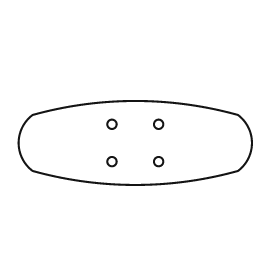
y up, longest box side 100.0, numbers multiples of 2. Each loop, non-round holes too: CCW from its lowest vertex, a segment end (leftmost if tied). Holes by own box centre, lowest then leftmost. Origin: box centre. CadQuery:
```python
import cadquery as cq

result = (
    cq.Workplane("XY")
    .moveTo(-44.0, -12.0)
    .threePointArc((0.0, -18.0), (44.0, -12.0))
    .threePointArc((50.0, 0.0), (44.0, 12.0))
    .threePointArc((0.0, 18.0), (-44.0, 12.0))
    .threePointArc((-50.0, 0.0), (-44.0, -12.0))
    .close()
    .moveTo(-10.0, -8.0)
    .circle(2.0)
    .moveTo(10.0, -8.0)
    .circle(2.0)
    .moveTo(-10.0, 8.0)
    .circle(2.0)
    .moveTo(10.0, 8.0)
    .circle(2.0)
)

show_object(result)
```